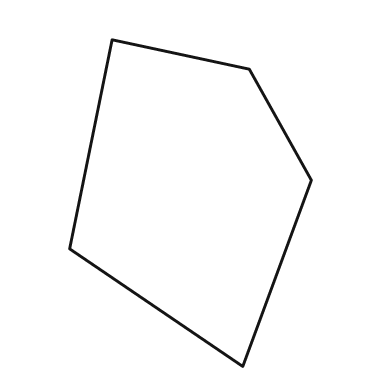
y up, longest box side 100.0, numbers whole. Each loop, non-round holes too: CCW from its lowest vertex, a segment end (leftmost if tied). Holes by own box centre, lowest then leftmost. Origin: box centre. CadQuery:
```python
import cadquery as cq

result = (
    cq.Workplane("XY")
    .moveTo(16.0, -50.0)
    .lineTo(37.0, 7.0)
    .lineTo(18.0, 41.0)
    .lineTo(-24.0, 50.0)
    .lineTo(-37.0, -14.0)
    .close()
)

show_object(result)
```